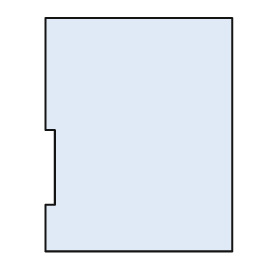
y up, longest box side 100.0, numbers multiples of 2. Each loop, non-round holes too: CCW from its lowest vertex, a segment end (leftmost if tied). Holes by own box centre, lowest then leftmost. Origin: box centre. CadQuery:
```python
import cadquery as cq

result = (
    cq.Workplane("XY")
    .moveTo(-40.0, -50.0)
    .lineTo(40.0, -50.0)
    .lineTo(40.0, 50.0)
    .lineTo(-40.0, 50.0)
    .lineTo(-40.0, 2.0)
    .lineTo(-36.0, 2.0)
    .lineTo(-36.0, -30.0)
    .lineTo(-40.0, -30.0)
    .close()
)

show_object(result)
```